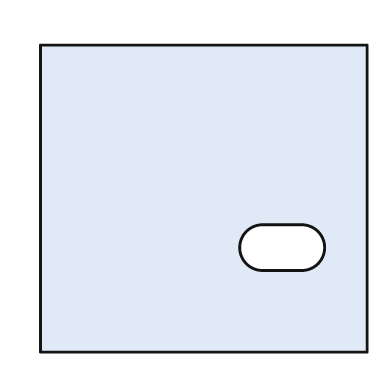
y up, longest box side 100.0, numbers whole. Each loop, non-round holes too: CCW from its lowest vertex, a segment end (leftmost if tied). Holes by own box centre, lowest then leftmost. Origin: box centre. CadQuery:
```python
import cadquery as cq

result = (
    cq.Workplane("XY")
    .moveTo(-50.0, -47.0)
    .lineTo(50.0, -47.0)
    .lineTo(50.0, 47.0)
    .lineTo(-50.0, 47.0)
    .close()
    .moveTo(18.0, -22.0)
    .lineTo(30.0, -22.0)
    .threePointArc((37.0, -15.0), (30.0, -8.0))
    .lineTo(18.0, -8.0)
    .threePointArc((11.0, -15.0), (18.0, -22.0))
    .close()
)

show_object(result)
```